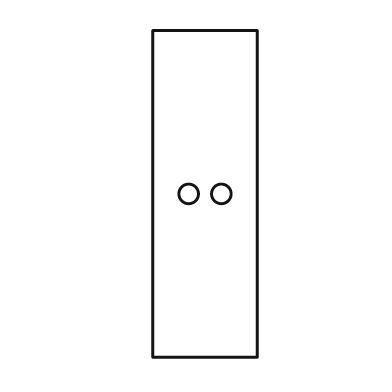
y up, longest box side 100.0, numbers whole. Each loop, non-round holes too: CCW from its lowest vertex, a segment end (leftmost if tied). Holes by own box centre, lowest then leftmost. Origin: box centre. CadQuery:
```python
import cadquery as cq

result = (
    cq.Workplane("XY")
    .moveTo(-16.0, -50.0)
    .lineTo(16.0, -50.0)
    .lineTo(16.0, 50.0)
    .lineTo(-16.0, 50.0)
    .close()
    .moveTo(-5.0, 0.0)
    .circle(3.0)
    .moveTo(5.0, 0.0)
    .circle(3.0)
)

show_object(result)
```